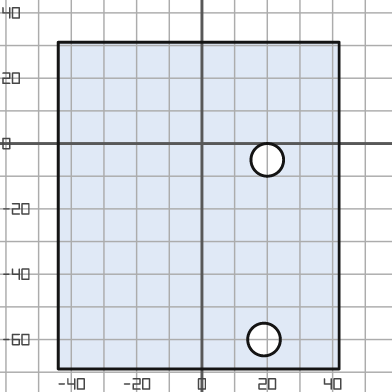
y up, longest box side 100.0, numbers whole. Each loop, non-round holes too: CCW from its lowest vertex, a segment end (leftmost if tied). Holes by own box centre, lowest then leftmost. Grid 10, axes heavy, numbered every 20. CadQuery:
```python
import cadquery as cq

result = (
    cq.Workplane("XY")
    .moveTo(-44.0, -69.0)
    .lineTo(42.0, -69.0)
    .lineTo(42.0, 31.0)
    .lineTo(-44.0, 31.0)
    .close()
    .moveTo(19.0, -60.0)
    .circle(5.0)
    .moveTo(20.0, -5.0)
    .circle(5.0)
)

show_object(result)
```